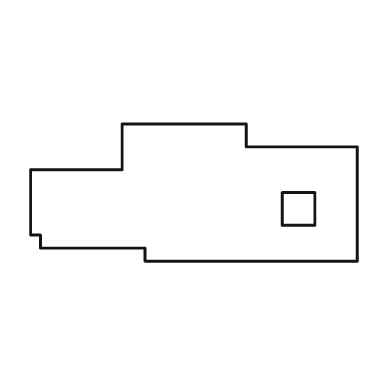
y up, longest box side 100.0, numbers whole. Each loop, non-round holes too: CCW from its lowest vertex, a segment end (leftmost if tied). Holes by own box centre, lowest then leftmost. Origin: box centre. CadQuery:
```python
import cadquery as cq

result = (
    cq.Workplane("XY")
    .moveTo(-15.0, -21.0)
    .lineTo(50.0, -21.0)
    .lineTo(50.0, 14.0)
    .lineTo(16.0, 14.0)
    .lineTo(16.0, 21.0)
    .lineTo(-22.0, 21.0)
    .lineTo(-22.0, 7.0)
    .lineTo(-50.0, 7.0)
    .lineTo(-50.0, -13.0)
    .lineTo(-47.0, -13.0)
    .lineTo(-47.0, -17.0)
    .lineTo(-15.0, -17.0)
    .close()
    .moveTo(27.0, -10.0)
    .lineTo(37.0, -10.0)
    .lineTo(37.0, 0.0)
    .lineTo(27.0, 0.0)
    .close()
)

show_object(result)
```